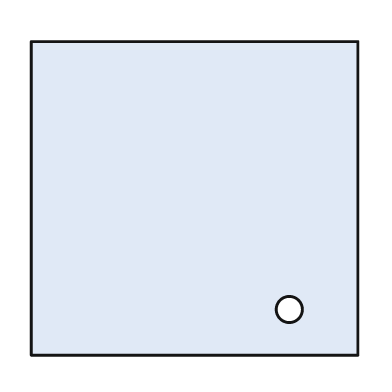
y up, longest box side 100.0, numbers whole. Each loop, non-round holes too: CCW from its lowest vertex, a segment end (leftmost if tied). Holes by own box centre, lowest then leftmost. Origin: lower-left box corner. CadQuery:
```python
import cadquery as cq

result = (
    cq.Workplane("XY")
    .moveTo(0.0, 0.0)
    .lineTo(100.0, 0.0)
    .lineTo(100.0, 96.0)
    .lineTo(0.0, 96.0)
    .close()
    .moveTo(79.0, 14.0)
    .circle(4.0)
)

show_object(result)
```